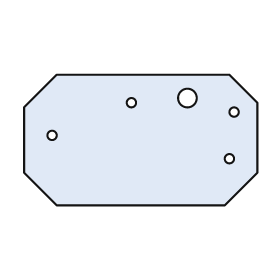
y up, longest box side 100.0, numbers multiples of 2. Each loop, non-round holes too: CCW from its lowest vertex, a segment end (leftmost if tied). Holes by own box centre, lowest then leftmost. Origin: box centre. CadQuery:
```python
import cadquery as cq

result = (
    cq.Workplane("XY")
    .moveTo(-36.0, -28.0)
    .lineTo(36.0, -28.0)
    .lineTo(50.0, -14.0)
    .lineTo(50.0, 16.0)
    .lineTo(38.0, 28.0)
    .lineTo(-36.0, 28.0)
    .lineTo(-50.0, 14.0)
    .lineTo(-50.0, -14.0)
    .close()
    .moveTo(38.0, -8.0)
    .circle(2.0)
    .moveTo(-38.0, 2.0)
    .circle(2.0)
    .moveTo(40.0, 12.0)
    .circle(2.0)
    .moveTo(-4.0, 16.0)
    .circle(2.0)
    .moveTo(20.0, 18.0)
    .circle(4.0)
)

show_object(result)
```